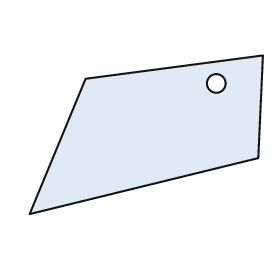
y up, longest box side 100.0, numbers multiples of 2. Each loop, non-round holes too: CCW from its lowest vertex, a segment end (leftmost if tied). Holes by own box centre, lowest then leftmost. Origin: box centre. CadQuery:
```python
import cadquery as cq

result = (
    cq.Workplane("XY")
    .moveTo(-50.0, -34.0)
    .lineTo(48.0, -10.0)
    .lineTo(50.0, 34.0)
    .lineTo(-26.0, 24.0)
    .close()
    .moveTo(30.0, 22.0)
    .circle(4.0)
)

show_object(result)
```